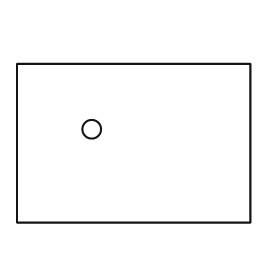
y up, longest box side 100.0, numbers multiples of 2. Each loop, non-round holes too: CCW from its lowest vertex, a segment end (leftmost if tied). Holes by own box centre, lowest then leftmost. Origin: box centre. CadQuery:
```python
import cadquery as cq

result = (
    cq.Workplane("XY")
    .moveTo(-50.0, -34.0)
    .lineTo(50.0, -34.0)
    .lineTo(50.0, 34.0)
    .lineTo(-50.0, 34.0)
    .close()
    .moveTo(-18.0, 6.0)
    .circle(4.0)
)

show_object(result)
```